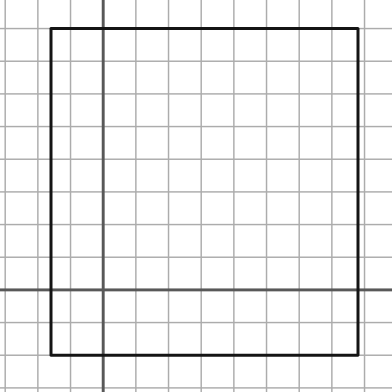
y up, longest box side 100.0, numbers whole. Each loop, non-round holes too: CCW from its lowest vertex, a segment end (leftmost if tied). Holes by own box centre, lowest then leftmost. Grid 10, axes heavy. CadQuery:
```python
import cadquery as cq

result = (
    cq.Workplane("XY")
    .moveTo(-16.0, -20.0)
    .lineTo(78.0, -20.0)
    .lineTo(78.0, 80.0)
    .lineTo(-16.0, 80.0)
    .close()
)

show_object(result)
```